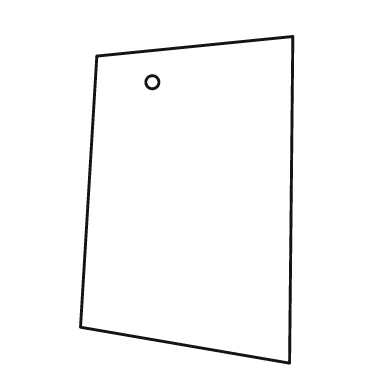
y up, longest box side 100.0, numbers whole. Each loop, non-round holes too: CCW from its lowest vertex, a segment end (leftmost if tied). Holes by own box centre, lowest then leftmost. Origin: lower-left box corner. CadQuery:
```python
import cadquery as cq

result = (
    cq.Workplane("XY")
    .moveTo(64.0, 0.0)
    .lineTo(65.0, 100.0)
    .lineTo(5.0, 94.0)
    .lineTo(0.0, 11.0)
    .close()
    .moveTo(22.0, 86.0)
    .circle(2.0)
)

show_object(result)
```